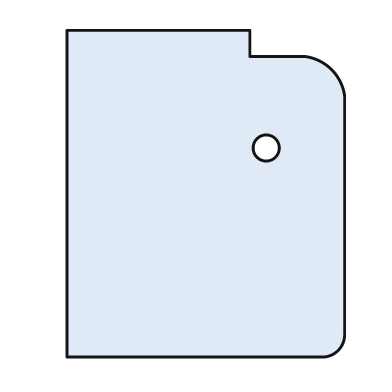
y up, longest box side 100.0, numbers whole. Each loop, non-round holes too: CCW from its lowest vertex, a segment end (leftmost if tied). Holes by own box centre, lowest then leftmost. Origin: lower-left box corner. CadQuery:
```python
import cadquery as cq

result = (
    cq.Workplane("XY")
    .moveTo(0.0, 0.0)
    .lineTo(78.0, 0.0)
    .threePointArc((83.0, 2.0), (85.0, 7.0))
    .lineTo(85.0, 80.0)
    .threePointArc((81.0, 88.0), (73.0, 92.0))
    .lineTo(56.0, 92.0)
    .lineTo(56.0, 100.0)
    .lineTo(0.0, 100.0)
    .close()
    .moveTo(61.0, 64.0)
    .circle(4.0)
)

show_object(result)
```